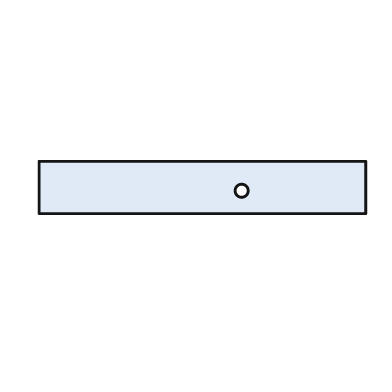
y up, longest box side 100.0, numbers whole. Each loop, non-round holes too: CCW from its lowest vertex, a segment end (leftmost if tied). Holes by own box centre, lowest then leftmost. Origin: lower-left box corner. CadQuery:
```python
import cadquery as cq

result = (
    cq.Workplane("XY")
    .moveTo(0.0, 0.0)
    .lineTo(100.0, 0.0)
    .lineTo(100.0, 16.0)
    .lineTo(0.0, 16.0)
    .close()
    .moveTo(62.0, 7.0)
    .circle(2.0)
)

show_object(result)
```